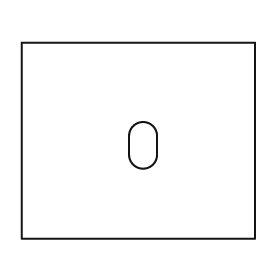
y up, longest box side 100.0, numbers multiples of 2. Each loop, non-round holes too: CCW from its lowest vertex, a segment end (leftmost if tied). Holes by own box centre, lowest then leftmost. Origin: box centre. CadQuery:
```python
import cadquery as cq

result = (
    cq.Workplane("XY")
    .moveTo(-50.0, -42.0)
    .lineTo(50.0, -42.0)
    .lineTo(50.0, 42.0)
    .lineTo(-50.0, 42.0)
    .close()
    .moveTo(-4.0, -6.0)
    .threePointArc((2.0, -12.0), (8.0, -6.0))
    .lineTo(8.0, 2.0)
    .threePointArc((2.0, 8.0), (-4.0, 2.0))
    .close()
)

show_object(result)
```